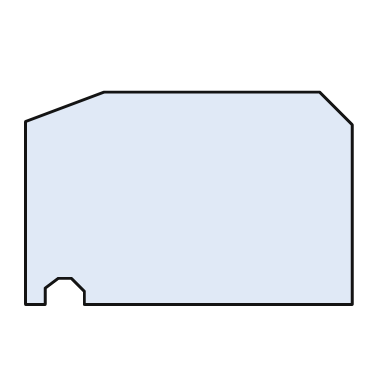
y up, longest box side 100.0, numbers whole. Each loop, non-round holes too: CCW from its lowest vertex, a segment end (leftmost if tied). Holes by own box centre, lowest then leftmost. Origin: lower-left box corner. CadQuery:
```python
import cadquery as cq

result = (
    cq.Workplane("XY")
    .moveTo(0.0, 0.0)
    .lineTo(6.0, 0.0)
    .lineTo(6.0, 5.0)
    .lineTo(10.0, 8.0)
    .lineTo(14.0, 8.0)
    .lineTo(18.0, 4.0)
    .lineTo(18.0, 0.0)
    .lineTo(100.0, 0.0)
    .lineTo(100.0, 55.0)
    .lineTo(90.0, 65.0)
    .lineTo(24.0, 65.0)
    .lineTo(0.0, 56.0)
    .close()
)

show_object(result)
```